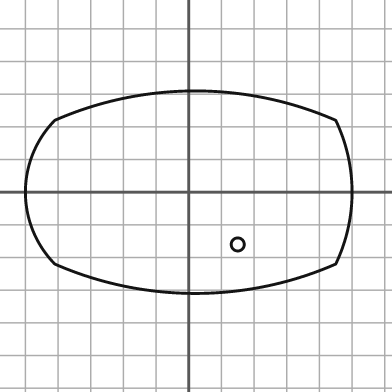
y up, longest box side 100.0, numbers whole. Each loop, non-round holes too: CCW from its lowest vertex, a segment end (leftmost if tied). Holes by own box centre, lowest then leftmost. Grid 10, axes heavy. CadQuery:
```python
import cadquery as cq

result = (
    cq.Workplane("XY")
    .moveTo(-41.0, -22.0)
    .threePointArc((2.0, -31.0), (45.0, -22.0))
    .threePointArc((50.0, 0.0), (45.0, 22.0))
    .threePointArc((2.0, 31.0), (-41.0, 22.0))
    .threePointArc((-50.0, 0.0), (-41.0, -22.0))
    .close()
    .moveTo(15.0, -16.0)
    .circle(2.0)
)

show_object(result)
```